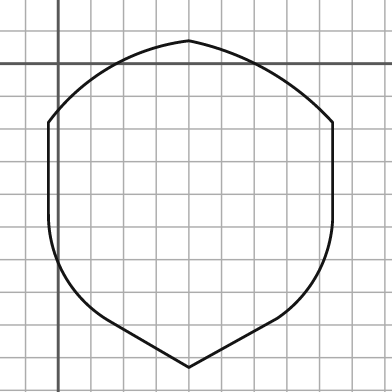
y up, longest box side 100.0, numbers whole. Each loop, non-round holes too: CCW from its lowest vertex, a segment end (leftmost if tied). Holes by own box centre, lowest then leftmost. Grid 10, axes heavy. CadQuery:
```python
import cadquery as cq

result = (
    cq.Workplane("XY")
    .moveTo(40.0, -93.0)
    .lineTo(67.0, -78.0)
    .threePointArc((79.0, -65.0), (84.0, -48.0))
    .lineTo(84.0, -18.0)
    .threePointArc((64.0, -2.0), (40.0, 7.0))
    .threePointArc((16.0, -1.0), (-3.0, -18.0))
    .lineTo(-3.0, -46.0)
    .threePointArc((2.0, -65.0), (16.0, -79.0))
    .close()
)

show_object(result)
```